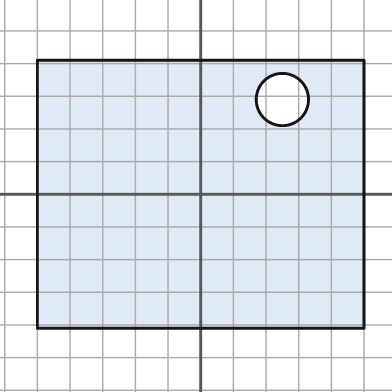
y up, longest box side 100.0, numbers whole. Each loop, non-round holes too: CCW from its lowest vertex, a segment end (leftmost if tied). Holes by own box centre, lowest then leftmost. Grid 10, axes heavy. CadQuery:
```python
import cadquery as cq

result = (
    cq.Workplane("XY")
    .moveTo(-50.0, -41.0)
    .lineTo(50.0, -41.0)
    .lineTo(50.0, 41.0)
    .lineTo(-50.0, 41.0)
    .close()
    .moveTo(25.0, 29.0)
    .circle(8.0)
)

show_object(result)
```